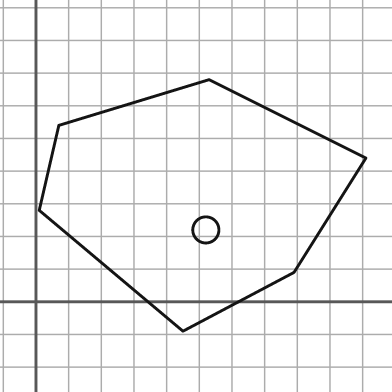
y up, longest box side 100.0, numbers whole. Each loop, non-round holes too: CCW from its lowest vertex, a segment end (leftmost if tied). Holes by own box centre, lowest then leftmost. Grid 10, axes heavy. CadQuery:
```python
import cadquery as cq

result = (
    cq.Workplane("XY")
    .moveTo(45.0, -9.0)
    .lineTo(79.0, 9.0)
    .lineTo(101.0, 44.0)
    .lineTo(53.0, 68.0)
    .lineTo(7.0, 54.0)
    .lineTo(1.0, 28.0)
    .close()
    .moveTo(52.0, 22.0)
    .circle(4.0)
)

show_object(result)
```